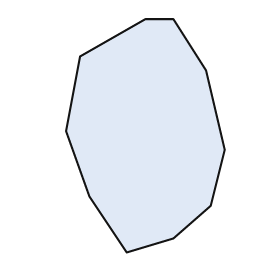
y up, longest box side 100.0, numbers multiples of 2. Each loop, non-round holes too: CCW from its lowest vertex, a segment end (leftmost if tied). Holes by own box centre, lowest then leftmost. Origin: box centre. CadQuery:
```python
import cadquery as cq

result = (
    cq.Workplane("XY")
    .moveTo(-8.0, -50.0)
    .lineTo(12.0, -44.0)
    .lineTo(28.0, -30.0)
    .lineTo(34.0, -6.0)
    .lineTo(26.0, 28.0)
    .lineTo(12.0, 50.0)
    .lineTo(0.0, 50.0)
    .lineTo(-28.0, 34.0)
    .lineTo(-34.0, 2.0)
    .lineTo(-24.0, -26.0)
    .close()
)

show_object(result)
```